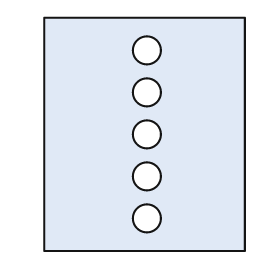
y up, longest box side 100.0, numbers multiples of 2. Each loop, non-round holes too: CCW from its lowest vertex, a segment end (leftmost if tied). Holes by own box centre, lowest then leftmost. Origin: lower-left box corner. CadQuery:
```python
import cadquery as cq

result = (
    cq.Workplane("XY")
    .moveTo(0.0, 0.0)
    .lineTo(86.0, 0.0)
    .lineTo(86.0, 100.0)
    .lineTo(0.0, 100.0)
    .close()
    .moveTo(44.0, 14.0)
    .circle(6.0)
    .moveTo(44.0, 32.0)
    .circle(6.0)
    .moveTo(44.0, 50.0)
    .circle(6.0)
    .moveTo(44.0, 68.0)
    .circle(6.0)
    .moveTo(44.0, 86.0)
    .circle(6.0)
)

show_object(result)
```